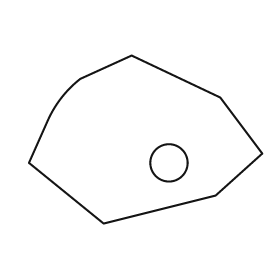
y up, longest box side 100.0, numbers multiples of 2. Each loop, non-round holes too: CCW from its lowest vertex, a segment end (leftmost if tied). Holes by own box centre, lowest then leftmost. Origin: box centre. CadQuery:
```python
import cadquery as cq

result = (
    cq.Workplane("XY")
    .moveTo(-18.0, -36.0)
    .lineTo(30.0, -24.0)
    .lineTo(50.0, -6.0)
    .lineTo(32.0, 18.0)
    .lineTo(-6.0, 36.0)
    .lineTo(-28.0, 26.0)
    .threePointArc((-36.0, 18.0), (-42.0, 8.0))
    .lineTo(-50.0, -10.0)
    .close()
    .moveTo(10.0, -10.0)
    .circle(8.0)
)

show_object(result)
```